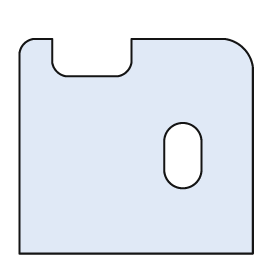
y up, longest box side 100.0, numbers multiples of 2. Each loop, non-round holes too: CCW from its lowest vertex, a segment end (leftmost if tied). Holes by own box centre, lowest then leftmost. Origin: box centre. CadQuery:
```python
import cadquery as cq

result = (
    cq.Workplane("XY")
    .moveTo(-50.0, -46.0)
    .lineTo(50.0, -46.0)
    .lineTo(50.0, 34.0)
    .threePointArc((46.0, 42.0), (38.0, 46.0))
    .lineTo(-2.0, 46.0)
    .lineTo(-2.0, 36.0)
    .threePointArc((-4.0, 32.0), (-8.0, 30.0))
    .lineTo(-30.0, 30.0)
    .threePointArc((-34.0, 32.0), (-36.0, 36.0))
    .lineTo(-36.0, 46.0)
    .lineTo(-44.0, 46.0)
    .threePointArc((-48.0, 44.0), (-50.0, 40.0))
    .close()
    .moveTo(12.0, -10.0)
    .threePointArc((20.0, -18.0), (28.0, -10.0))
    .lineTo(28.0, 2.0)
    .threePointArc((20.0, 10.0), (12.0, 2.0))
    .close()
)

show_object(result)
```